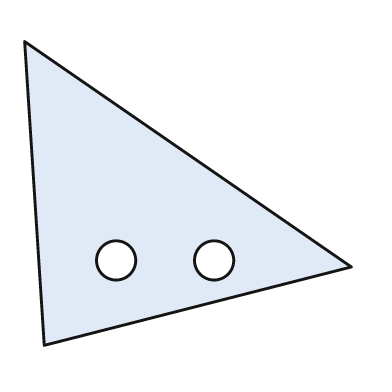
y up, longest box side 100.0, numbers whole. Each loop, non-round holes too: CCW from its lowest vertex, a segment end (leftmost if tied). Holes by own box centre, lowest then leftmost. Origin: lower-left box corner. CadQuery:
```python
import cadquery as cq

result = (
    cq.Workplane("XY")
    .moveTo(6.0, 0.0)
    .lineTo(100.0, 24.0)
    .lineTo(0.0, 93.0)
    .close()
    .moveTo(28.0, 26.0)
    .circle(6.0)
    .moveTo(58.0, 26.0)
    .circle(6.0)
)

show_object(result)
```